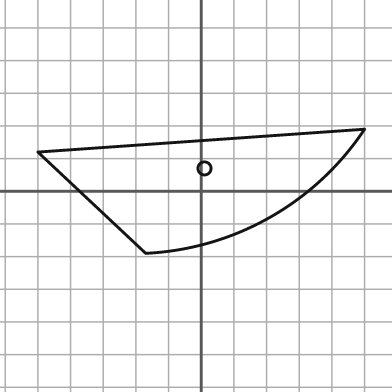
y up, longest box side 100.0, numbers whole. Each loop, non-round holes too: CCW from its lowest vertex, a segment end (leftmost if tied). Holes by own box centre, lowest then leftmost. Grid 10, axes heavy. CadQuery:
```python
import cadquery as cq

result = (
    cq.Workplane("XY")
    .moveTo(-17.0, -19.0)
    .threePointArc((21.0, -8.0), (50.0, 19.0))
    .lineTo(-50.0, 12.0)
    .close()
    .moveTo(1.0, 7.0)
    .circle(2.0)
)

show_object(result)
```